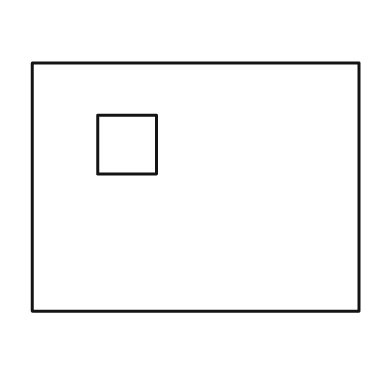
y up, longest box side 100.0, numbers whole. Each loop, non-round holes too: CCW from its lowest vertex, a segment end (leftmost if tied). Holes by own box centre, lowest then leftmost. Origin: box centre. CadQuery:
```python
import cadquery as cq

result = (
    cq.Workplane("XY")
    .moveTo(-50.0, -38.0)
    .lineTo(50.0, -38.0)
    .lineTo(50.0, 38.0)
    .lineTo(-50.0, 38.0)
    .close()
    .moveTo(-30.0, 4.0)
    .lineTo(-12.0, 4.0)
    .lineTo(-12.0, 22.0)
    .lineTo(-30.0, 22.0)
    .close()
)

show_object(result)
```